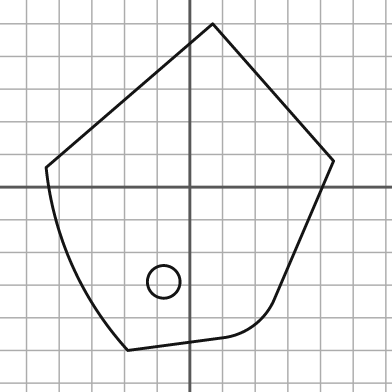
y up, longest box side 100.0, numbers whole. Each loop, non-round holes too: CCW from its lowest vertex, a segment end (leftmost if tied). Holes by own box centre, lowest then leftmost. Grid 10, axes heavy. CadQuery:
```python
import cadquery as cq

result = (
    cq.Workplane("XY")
    .moveTo(-19.0, -50.0)
    .lineTo(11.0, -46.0)
    .threePointArc((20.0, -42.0), (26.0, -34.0))
    .lineTo(44.0, 8.0)
    .lineTo(7.0, 50.0)
    .lineTo(-44.0, 6.0)
    .threePointArc((-36.0, -24.0), (-19.0, -50.0))
    .close()
    .moveTo(-8.0, -29.0)
    .circle(5.0)
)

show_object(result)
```